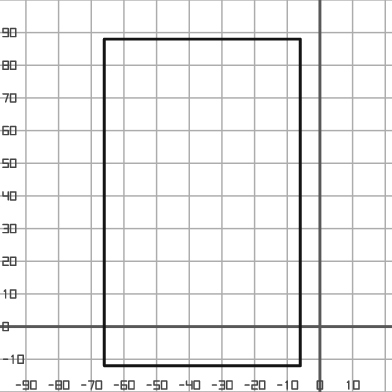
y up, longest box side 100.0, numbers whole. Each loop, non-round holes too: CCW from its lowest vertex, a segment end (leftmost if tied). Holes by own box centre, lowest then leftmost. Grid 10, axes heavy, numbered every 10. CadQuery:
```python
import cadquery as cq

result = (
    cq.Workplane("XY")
    .moveTo(-66.0, -12.0)
    .lineTo(-6.0, -12.0)
    .lineTo(-6.0, 88.0)
    .lineTo(-66.0, 88.0)
    .close()
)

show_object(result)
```